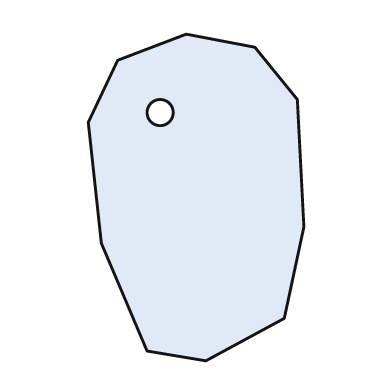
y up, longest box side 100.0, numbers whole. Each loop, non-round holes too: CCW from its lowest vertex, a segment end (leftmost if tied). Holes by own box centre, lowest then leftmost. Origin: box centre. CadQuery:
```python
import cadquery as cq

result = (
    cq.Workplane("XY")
    .moveTo(3.0, -50.0)
    .lineTo(27.0, -37.0)
    .lineTo(33.0, -9.0)
    .lineTo(31.0, 30.0)
    .lineTo(18.0, 46.0)
    .lineTo(-3.0, 50.0)
    .lineTo(-24.0, 42.0)
    .lineTo(-33.0, 23.0)
    .lineTo(-29.0, -14.0)
    .lineTo(-15.0, -47.0)
    .close()
    .moveTo(-11.0, 26.0)
    .circle(4.0)
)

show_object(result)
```